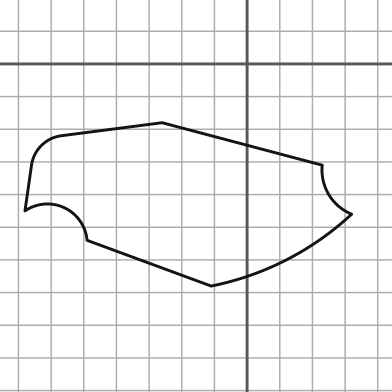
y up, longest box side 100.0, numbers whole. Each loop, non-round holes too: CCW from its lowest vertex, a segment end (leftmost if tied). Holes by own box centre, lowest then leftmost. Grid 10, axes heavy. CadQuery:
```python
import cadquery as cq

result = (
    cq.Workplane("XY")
    .moveTo(-11.0, -68.0)
    .threePointArc((12.0, -60.0), (32.0, -46.0))
    .threePointArc((25.0, -40.0), (23.0, -31.0))
    .lineTo(-26.0, -18.0)
    .lineTo(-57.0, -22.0)
    .threePointArc((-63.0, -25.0), (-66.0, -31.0))
    .lineTo(-68.0, -45.0)
    .threePointArc((-56.0, -44.0), (-49.0, -54.0))
    .close()
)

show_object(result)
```